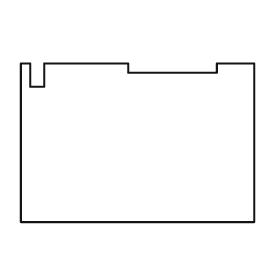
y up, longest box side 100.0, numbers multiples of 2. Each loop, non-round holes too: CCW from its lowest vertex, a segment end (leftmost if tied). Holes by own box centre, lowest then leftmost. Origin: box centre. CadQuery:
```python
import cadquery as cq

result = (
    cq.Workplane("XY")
    .moveTo(-50.0, -34.0)
    .lineTo(50.0, -34.0)
    .lineTo(50.0, 34.0)
    .lineTo(34.0, 34.0)
    .lineTo(34.0, 30.0)
    .lineTo(-4.0, 30.0)
    .lineTo(-4.0, 34.0)
    .lineTo(-40.0, 34.0)
    .lineTo(-40.0, 24.0)
    .lineTo(-46.0, 24.0)
    .lineTo(-46.0, 34.0)
    .lineTo(-50.0, 34.0)
    .close()
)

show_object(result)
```